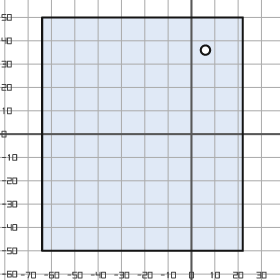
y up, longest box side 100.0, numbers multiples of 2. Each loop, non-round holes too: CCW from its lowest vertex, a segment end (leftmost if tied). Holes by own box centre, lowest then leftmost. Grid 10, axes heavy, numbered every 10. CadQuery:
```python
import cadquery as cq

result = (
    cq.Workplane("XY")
    .moveTo(-64.0, -50.0)
    .lineTo(22.0, -50.0)
    .lineTo(22.0, 50.0)
    .lineTo(-64.0, 50.0)
    .close()
    .moveTo(6.0, 36.0)
    .circle(2.0)
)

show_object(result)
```